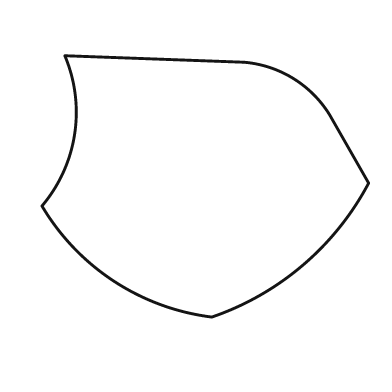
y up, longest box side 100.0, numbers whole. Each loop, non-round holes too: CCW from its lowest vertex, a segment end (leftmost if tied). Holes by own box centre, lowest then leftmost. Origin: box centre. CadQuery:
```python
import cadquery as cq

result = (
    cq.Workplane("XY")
    .moveTo(2.0, -40.0)
    .threePointArc((30.0, -24.0), (50.0, 1.0))
    .lineTo(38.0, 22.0)
    .threePointArc((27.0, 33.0), (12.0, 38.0))
    .lineTo(-43.0, 40.0)
    .threePointArc((-40.0, 16.0), (-50.0, -6.0))
    .threePointArc((-28.0, -29.0), (2.0, -40.0))
    .close()
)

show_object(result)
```